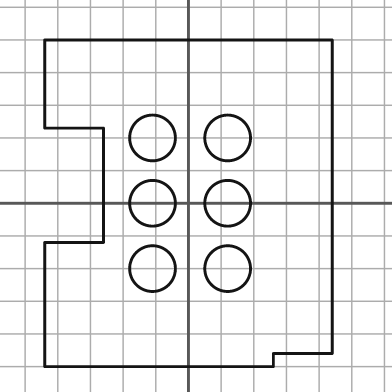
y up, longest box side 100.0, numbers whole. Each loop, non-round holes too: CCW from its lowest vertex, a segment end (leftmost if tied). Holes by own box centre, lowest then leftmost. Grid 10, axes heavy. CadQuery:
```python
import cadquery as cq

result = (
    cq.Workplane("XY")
    .moveTo(-44.0, -50.0)
    .lineTo(26.0, -50.0)
    .lineTo(26.0, -46.0)
    .lineTo(44.0, -46.0)
    .lineTo(44.0, 50.0)
    .lineTo(-44.0, 50.0)
    .lineTo(-44.0, 23.0)
    .lineTo(-26.0, 23.0)
    .lineTo(-26.0, -12.0)
    .lineTo(-44.0, -12.0)
    .close()
    .moveTo(-11.0, -20.0)
    .circle(7.0)
    .moveTo(12.0, -20.0)
    .circle(7.0)
    .moveTo(-11.0, 0.0)
    .circle(7.0)
    .moveTo(12.0, 0.0)
    .circle(7.0)
    .moveTo(-11.0, 20.0)
    .circle(7.0)
    .moveTo(12.0, 20.0)
    .circle(7.0)
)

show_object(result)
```